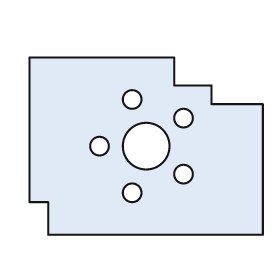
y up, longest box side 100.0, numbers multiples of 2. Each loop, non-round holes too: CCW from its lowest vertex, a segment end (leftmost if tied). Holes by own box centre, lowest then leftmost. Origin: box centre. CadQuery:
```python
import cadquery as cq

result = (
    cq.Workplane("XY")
    .moveTo(-42.0, -38.0)
    .lineTo(50.0, -38.0)
    .lineTo(50.0, 18.0)
    .lineTo(28.0, 18.0)
    .lineTo(28.0, 26.0)
    .lineTo(12.0, 26.0)
    .lineTo(12.0, 38.0)
    .lineTo(-50.0, 38.0)
    .lineTo(-50.0, -24.0)
    .lineTo(-42.0, -24.0)
    .close()
    .moveTo(-6.0, -20.0)
    .circle(4.0)
    .moveTo(16.0, -12.0)
    .circle(4.0)
    .moveTo(-20.0, 0.0)
    .circle(4.0)
    .moveTo(0.0, 0.0)
    .circle(10.0)
    .moveTo(16.0, 12.0)
    .circle(4.0)
    .moveTo(-6.0, 20.0)
    .circle(4.0)
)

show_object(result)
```